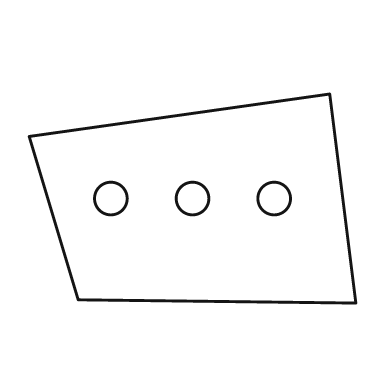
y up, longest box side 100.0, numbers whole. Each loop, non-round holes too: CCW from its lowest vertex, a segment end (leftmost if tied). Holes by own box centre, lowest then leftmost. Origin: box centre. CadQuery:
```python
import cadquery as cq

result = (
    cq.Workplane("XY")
    .moveTo(50.0, -32.0)
    .lineTo(42.0, 32.0)
    .lineTo(-50.0, 19.0)
    .lineTo(-35.0, -31.0)
    .close()
    .moveTo(-25.0, 0.0)
    .circle(5.0)
    .moveTo(0.0, 0.0)
    .circle(5.0)
    .moveTo(25.0, 0.0)
    .circle(5.0)
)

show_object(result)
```